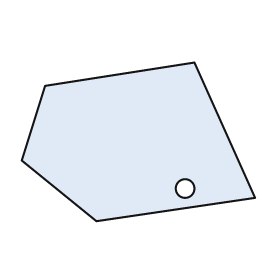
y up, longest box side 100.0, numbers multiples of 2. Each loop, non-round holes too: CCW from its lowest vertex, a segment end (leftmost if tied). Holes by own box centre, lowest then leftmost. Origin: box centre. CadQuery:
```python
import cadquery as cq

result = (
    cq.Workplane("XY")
    .moveTo(-18.0, -34.0)
    .lineTo(50.0, -24.0)
    .lineTo(24.0, 34.0)
    .lineTo(-40.0, 24.0)
    .lineTo(-50.0, -8.0)
    .close()
    .moveTo(20.0, -20.0)
    .circle(4.0)
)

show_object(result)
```